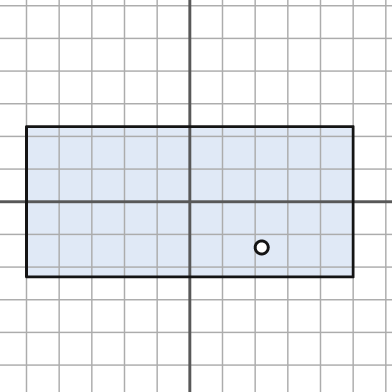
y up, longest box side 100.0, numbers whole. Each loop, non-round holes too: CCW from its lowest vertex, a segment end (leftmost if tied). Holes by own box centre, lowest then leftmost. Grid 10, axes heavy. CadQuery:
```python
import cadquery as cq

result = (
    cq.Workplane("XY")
    .moveTo(-50.0, -23.0)
    .lineTo(50.0, -23.0)
    .lineTo(50.0, 23.0)
    .lineTo(-50.0, 23.0)
    .close()
    .moveTo(22.0, -14.0)
    .circle(2.0)
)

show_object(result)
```